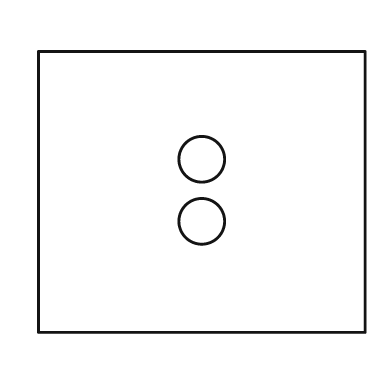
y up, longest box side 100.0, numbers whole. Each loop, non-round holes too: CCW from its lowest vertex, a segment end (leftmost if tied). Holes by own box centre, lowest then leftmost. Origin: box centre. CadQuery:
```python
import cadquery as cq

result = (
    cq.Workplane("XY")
    .moveTo(-50.0, -43.0)
    .lineTo(50.0, -43.0)
    .lineTo(50.0, 43.0)
    .lineTo(-50.0, 43.0)
    .close()
    .moveTo(0.0, -9.0)
    .circle(7.0)
    .moveTo(0.0, 10.0)
    .circle(7.0)
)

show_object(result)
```